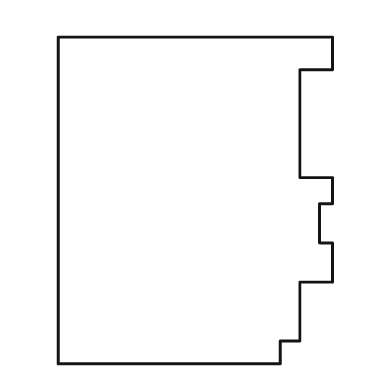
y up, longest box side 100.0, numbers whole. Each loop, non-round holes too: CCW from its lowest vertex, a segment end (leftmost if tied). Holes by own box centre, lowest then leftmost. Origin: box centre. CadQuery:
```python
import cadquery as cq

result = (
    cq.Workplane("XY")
    .moveTo(-42.0, -50.0)
    .lineTo(26.0, -50.0)
    .lineTo(26.0, -43.0)
    .lineTo(32.0, -43.0)
    .lineTo(32.0, -25.0)
    .lineTo(42.0, -25.0)
    .lineTo(42.0, -13.0)
    .lineTo(38.0, -13.0)
    .lineTo(38.0, -1.0)
    .lineTo(42.0, -1.0)
    .lineTo(42.0, 7.0)
    .lineTo(32.0, 7.0)
    .lineTo(32.0, 40.0)
    .lineTo(42.0, 40.0)
    .lineTo(42.0, 50.0)
    .lineTo(-42.0, 50.0)
    .close()
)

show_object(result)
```